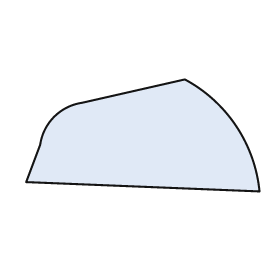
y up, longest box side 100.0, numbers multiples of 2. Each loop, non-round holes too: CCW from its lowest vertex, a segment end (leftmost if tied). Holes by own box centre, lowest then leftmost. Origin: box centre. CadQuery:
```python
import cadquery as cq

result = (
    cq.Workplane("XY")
    .moveTo(50.0, -24.0)
    .threePointArc((40.0, 4.0), (18.0, 24.0))
    .lineTo(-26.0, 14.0)
    .threePointArc((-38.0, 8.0), (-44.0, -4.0))
    .lineTo(-50.0, -20.0)
    .close()
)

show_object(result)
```